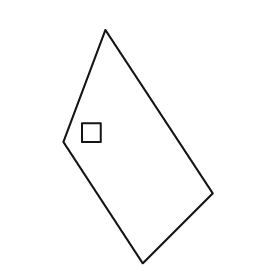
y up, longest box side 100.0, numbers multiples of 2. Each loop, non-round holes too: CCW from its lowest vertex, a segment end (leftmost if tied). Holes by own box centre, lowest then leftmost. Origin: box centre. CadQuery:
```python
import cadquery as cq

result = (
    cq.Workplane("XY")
    .moveTo(2.0, -50.0)
    .lineTo(32.0, -20.0)
    .lineTo(-14.0, 50.0)
    .lineTo(-32.0, 2.0)
    .close()
    .moveTo(-24.0, 2.0)
    .lineTo(-16.0, 2.0)
    .lineTo(-16.0, 10.0)
    .lineTo(-24.0, 10.0)
    .close()
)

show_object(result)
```